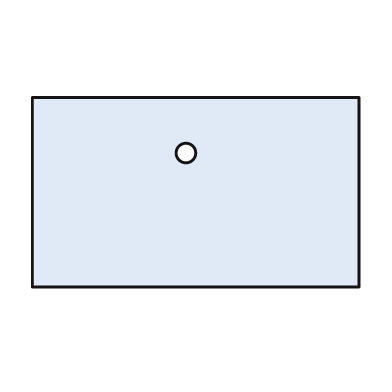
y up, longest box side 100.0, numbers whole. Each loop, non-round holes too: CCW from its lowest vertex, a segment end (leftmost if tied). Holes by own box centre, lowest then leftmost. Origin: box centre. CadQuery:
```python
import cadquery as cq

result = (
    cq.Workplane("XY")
    .moveTo(-50.0, -29.0)
    .lineTo(50.0, -29.0)
    .lineTo(50.0, 29.0)
    .lineTo(-50.0, 29.0)
    .close()
    .moveTo(-3.0, 12.0)
    .circle(3.0)
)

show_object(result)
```